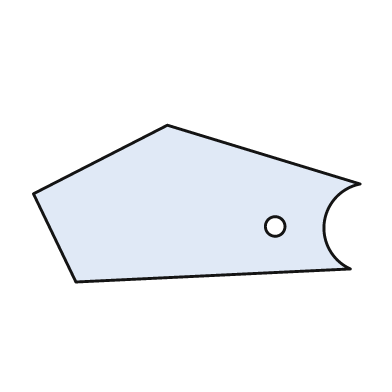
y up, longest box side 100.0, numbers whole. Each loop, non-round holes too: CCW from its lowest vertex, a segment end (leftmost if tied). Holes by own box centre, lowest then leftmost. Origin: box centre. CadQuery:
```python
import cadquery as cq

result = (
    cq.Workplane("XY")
    .moveTo(-37.0, -24.0)
    .lineTo(47.0, -20.0)
    .threePointArc((39.0, -6.0), (50.0, 6.0))
    .lineTo(-9.0, 24.0)
    .lineTo(-50.0, 3.0)
    .close()
    .moveTo(24.0, -7.0)
    .circle(3.0)
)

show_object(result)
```